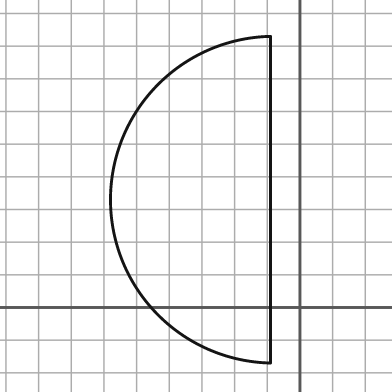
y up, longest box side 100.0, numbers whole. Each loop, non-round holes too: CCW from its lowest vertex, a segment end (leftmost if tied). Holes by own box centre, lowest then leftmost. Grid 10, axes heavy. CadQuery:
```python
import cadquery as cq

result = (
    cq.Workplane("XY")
    .moveTo(-9.0, -17.0)
    .lineTo(-9.0, 83.0)
    .threePointArc((-58.0, 33.0), (-9.0, -17.0))
    .close()
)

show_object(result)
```